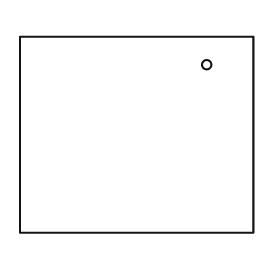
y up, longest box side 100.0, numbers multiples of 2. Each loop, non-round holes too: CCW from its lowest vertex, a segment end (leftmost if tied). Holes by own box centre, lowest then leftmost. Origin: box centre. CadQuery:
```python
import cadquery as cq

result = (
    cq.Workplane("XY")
    .moveTo(-50.0, -42.0)
    .lineTo(50.0, -42.0)
    .lineTo(50.0, 42.0)
    .lineTo(-50.0, 42.0)
    .close()
    .moveTo(30.0, 30.0)
    .circle(2.0)
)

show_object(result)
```